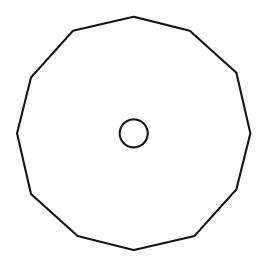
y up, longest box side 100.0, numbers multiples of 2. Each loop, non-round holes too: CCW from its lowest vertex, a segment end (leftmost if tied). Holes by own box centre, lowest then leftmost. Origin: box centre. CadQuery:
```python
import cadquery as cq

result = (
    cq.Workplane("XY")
    .moveTo(0.0, -50.0)
    .lineTo(26.0, -44.0)
    .lineTo(44.0, -24.0)
    .lineTo(50.0, 0.0)
    .lineTo(44.0, 26.0)
    .lineTo(24.0, 44.0)
    .lineTo(0.0, 50.0)
    .lineTo(-26.0, 44.0)
    .lineTo(-44.0, 24.0)
    .lineTo(-50.0, 0.0)
    .lineTo(-44.0, -26.0)
    .lineTo(-24.0, -44.0)
    .close()
    .moveTo(0.0, 0.0)
    .circle(6.0)
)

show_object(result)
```